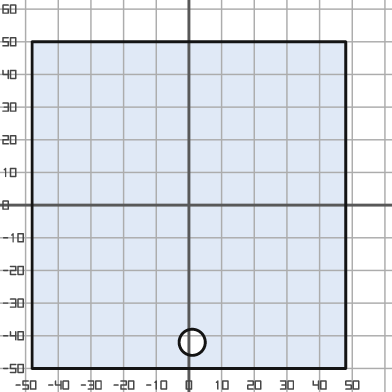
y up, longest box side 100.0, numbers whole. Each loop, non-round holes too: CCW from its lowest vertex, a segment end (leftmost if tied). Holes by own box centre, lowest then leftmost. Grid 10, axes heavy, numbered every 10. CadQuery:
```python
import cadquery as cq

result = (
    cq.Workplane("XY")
    .moveTo(-48.0, -50.0)
    .lineTo(48.0, -50.0)
    .lineTo(48.0, 50.0)
    .lineTo(-48.0, 50.0)
    .close()
    .moveTo(1.0, -42.0)
    .circle(4.0)
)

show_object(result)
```